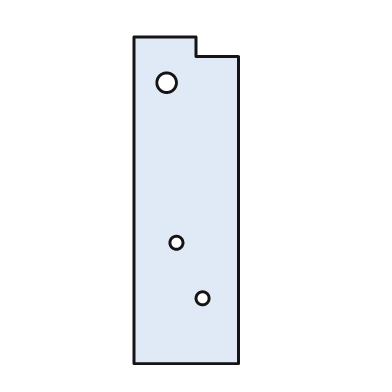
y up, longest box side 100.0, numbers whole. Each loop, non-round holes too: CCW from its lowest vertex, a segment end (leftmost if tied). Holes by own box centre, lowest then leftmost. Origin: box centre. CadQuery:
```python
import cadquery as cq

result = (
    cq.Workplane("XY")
    .moveTo(-16.0, -50.0)
    .lineTo(16.0, -50.0)
    .lineTo(16.0, 44.0)
    .lineTo(3.0, 44.0)
    .lineTo(3.0, 50.0)
    .lineTo(-16.0, 50.0)
    .close()
    .moveTo(5.0, -30.0)
    .circle(2.0)
    .moveTo(-3.0, -13.0)
    .circle(2.0)
    .moveTo(-6.0, 36.0)
    .circle(3.0)
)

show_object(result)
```